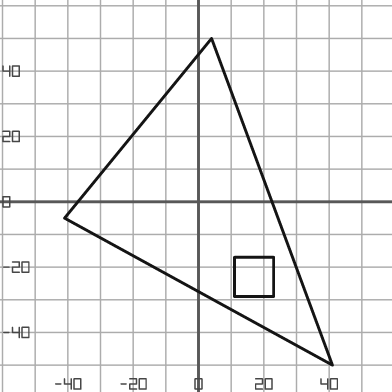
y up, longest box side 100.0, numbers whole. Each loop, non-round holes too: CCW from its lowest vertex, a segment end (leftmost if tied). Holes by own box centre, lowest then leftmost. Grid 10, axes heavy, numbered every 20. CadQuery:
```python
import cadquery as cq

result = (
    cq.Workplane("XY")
    .moveTo(41.0, -50.0)
    .lineTo(4.0, 50.0)
    .lineTo(-41.0, -5.0)
    .close()
    .moveTo(11.0, -29.0)
    .lineTo(23.0, -29.0)
    .lineTo(23.0, -17.0)
    .lineTo(11.0, -17.0)
    .close()
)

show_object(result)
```